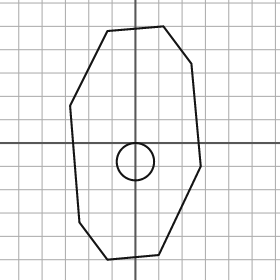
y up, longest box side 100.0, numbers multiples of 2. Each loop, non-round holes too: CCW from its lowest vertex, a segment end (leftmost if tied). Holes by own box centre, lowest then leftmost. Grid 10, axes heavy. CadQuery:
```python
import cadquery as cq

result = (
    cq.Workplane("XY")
    .moveTo(-12.0, -50.0)
    .lineTo(10.0, -48.0)
    .lineTo(28.0, -10.0)
    .lineTo(24.0, 34.0)
    .lineTo(12.0, 50.0)
    .lineTo(-12.0, 48.0)
    .lineTo(-28.0, 16.0)
    .lineTo(-24.0, -34.0)
    .close()
    .moveTo(0.0, -8.0)
    .circle(8.0)
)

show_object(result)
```